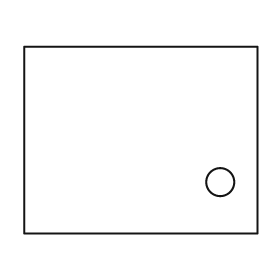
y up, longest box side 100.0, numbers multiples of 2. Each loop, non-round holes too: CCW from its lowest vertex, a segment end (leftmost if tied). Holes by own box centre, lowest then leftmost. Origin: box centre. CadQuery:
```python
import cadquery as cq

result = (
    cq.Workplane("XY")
    .moveTo(-50.0, -40.0)
    .lineTo(50.0, -40.0)
    .lineTo(50.0, 40.0)
    .lineTo(-50.0, 40.0)
    .close()
    .moveTo(34.0, -18.0)
    .circle(6.0)
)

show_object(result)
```